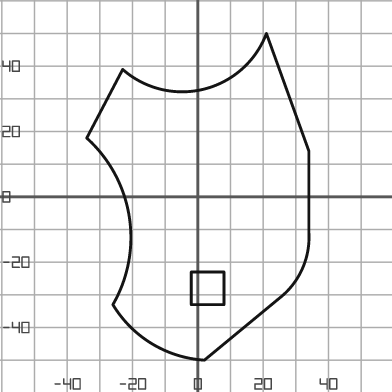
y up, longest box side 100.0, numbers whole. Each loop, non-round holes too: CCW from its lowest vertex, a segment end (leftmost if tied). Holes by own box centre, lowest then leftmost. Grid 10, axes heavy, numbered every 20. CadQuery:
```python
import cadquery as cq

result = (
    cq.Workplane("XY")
    .moveTo(2.0, -50.0)
    .lineTo(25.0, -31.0)
    .threePointArc((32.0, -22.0), (34.0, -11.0))
    .lineTo(34.0, 14.0)
    .lineTo(21.0, 50.0)
    .threePointArc((2.0, 33.0), (-23.0, 39.0))
    .lineTo(-34.0, 18.0)
    .threePointArc((-21.0, -6.0), (-26.0, -33.0))
    .threePointArc((-14.0, -45.0), (2.0, -50.0))
    .close()
    .moveTo(-2.0, -33.0)
    .lineTo(8.0, -33.0)
    .lineTo(8.0, -23.0)
    .lineTo(-2.0, -23.0)
    .close()
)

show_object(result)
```